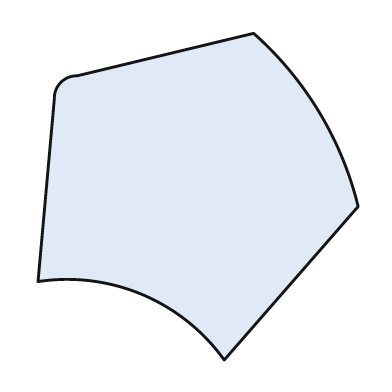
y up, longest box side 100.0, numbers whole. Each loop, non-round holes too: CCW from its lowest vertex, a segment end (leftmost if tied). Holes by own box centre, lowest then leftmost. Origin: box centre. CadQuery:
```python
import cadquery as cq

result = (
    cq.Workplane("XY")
    .moveTo(8.0, -50.0)
    .lineTo(49.0, -3.0)
    .threePointArc((37.0, 26.0), (17.0, 50.0))
    .lineTo(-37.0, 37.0)
    .threePointArc((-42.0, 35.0), (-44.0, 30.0))
    .lineTo(-49.0, -26.0)
    .threePointArc((-17.0, -30.0), (8.0, -50.0))
    .close()
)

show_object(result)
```